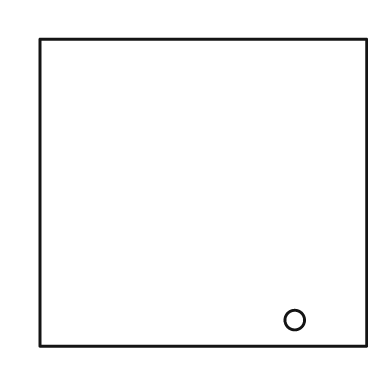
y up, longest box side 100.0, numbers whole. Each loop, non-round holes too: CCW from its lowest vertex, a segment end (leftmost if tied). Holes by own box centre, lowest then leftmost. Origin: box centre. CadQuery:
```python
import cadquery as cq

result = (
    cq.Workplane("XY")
    .moveTo(-50.0, -47.0)
    .lineTo(50.0, -47.0)
    .lineTo(50.0, 47.0)
    .lineTo(-50.0, 47.0)
    .close()
    .moveTo(28.0, -39.0)
    .circle(3.0)
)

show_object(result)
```